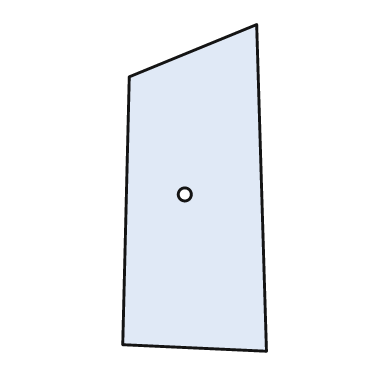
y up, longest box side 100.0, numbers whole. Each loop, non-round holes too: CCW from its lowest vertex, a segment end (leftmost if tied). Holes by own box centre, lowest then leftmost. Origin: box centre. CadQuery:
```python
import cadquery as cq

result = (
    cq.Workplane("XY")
    .moveTo(22.0, -50.0)
    .lineTo(19.0, 50.0)
    .lineTo(-20.0, 34.0)
    .lineTo(-22.0, -48.0)
    .close()
    .moveTo(-3.0, -2.0)
    .circle(2.0)
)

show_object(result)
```